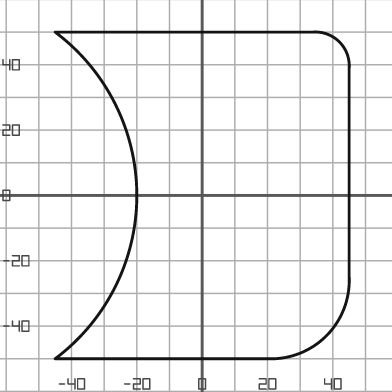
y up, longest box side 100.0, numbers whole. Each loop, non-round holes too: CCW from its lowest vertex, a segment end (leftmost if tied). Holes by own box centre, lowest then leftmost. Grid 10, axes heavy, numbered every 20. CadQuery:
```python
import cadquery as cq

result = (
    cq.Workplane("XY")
    .moveTo(-45.0, -50.0)
    .lineTo(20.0, -50.0)
    .threePointArc((38.0, -43.0), (45.0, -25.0))
    .lineTo(45.0, 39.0)
    .threePointArc((42.0, 47.0), (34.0, 50.0))
    .lineTo(-45.0, 50.0)
    .threePointArc((-20.0, 0.0), (-45.0, -50.0))
    .close()
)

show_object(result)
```